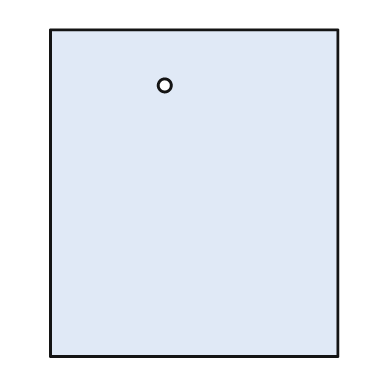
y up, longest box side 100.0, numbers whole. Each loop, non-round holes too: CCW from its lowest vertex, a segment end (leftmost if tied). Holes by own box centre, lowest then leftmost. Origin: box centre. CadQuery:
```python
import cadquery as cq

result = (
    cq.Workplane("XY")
    .moveTo(-44.0, -50.0)
    .lineTo(44.0, -50.0)
    .lineTo(44.0, 50.0)
    .lineTo(-44.0, 50.0)
    .close()
    .moveTo(-9.0, 33.0)
    .circle(2.0)
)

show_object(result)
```